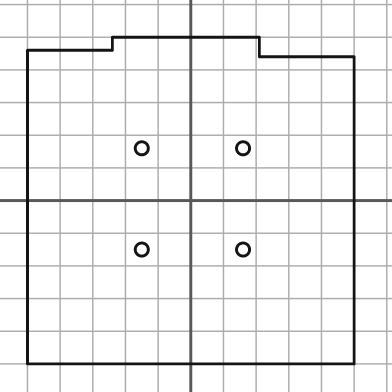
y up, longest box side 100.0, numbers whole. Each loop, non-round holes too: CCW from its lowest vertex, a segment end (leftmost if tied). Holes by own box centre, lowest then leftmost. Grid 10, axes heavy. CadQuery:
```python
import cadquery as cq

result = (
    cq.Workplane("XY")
    .moveTo(-50.0, -50.0)
    .lineTo(50.0, -50.0)
    .lineTo(50.0, 44.0)
    .lineTo(21.0, 44.0)
    .lineTo(21.0, 50.0)
    .lineTo(-24.0, 50.0)
    .lineTo(-24.0, 46.0)
    .lineTo(-50.0, 46.0)
    .close()
    .moveTo(-15.0, -15.0)
    .circle(2.0)
    .moveTo(16.0, -15.0)
    .circle(2.0)
    .moveTo(-15.0, 16.0)
    .circle(2.0)
    .moveTo(16.0, 16.0)
    .circle(2.0)
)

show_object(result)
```